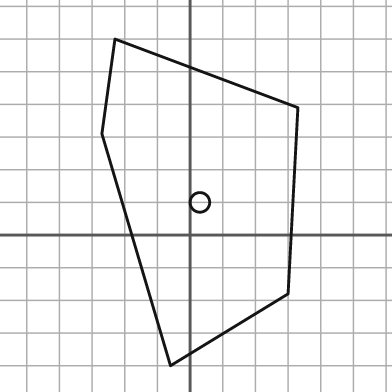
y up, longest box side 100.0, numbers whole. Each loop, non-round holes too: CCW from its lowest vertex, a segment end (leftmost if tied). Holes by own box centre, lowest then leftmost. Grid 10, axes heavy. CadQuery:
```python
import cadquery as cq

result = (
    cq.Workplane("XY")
    .moveTo(-6.0, -40.0)
    .lineTo(30.0, -18.0)
    .lineTo(33.0, 39.0)
    .lineTo(-23.0, 60.0)
    .lineTo(-27.0, 31.0)
    .close()
    .moveTo(3.0, 10.0)
    .circle(3.0)
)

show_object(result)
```